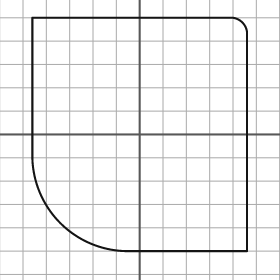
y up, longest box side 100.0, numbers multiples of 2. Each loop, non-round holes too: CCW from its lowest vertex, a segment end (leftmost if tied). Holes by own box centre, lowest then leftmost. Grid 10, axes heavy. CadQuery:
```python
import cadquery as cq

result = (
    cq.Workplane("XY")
    .moveTo(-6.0, -50.0)
    .lineTo(46.0, -50.0)
    .lineTo(46.0, 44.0)
    .threePointArc((44.0, 48.0), (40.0, 50.0))
    .lineTo(-46.0, 50.0)
    .lineTo(-46.0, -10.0)
    .threePointArc((-34.0, -38.0), (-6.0, -50.0))
    .close()
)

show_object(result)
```